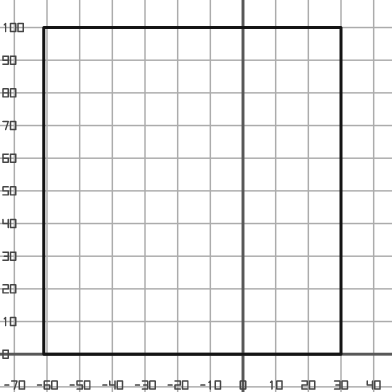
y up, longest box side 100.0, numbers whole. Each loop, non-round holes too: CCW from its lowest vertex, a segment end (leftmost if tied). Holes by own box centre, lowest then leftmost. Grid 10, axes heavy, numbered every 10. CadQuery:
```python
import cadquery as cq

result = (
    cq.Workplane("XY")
    .moveTo(-61.0, 0.0)
    .lineTo(30.0, 0.0)
    .lineTo(30.0, 100.0)
    .lineTo(-61.0, 100.0)
    .close()
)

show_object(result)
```